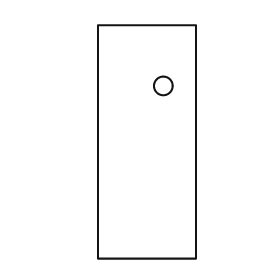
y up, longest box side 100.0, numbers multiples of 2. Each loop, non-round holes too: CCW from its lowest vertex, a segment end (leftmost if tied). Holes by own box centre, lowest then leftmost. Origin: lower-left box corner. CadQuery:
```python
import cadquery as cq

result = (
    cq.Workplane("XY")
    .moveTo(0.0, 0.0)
    .lineTo(42.0, 0.0)
    .lineTo(42.0, 100.0)
    .lineTo(0.0, 100.0)
    .close()
    .moveTo(28.0, 74.0)
    .circle(4.0)
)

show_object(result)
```